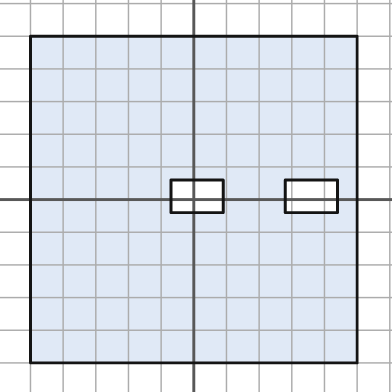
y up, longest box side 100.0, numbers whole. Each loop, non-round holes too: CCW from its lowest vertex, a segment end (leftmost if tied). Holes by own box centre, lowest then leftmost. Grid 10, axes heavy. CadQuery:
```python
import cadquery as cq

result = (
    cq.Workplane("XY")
    .moveTo(-50.0, -50.0)
    .lineTo(50.0, -50.0)
    .lineTo(50.0, 50.0)
    .lineTo(-50.0, 50.0)
    .close()
    .moveTo(-7.0, -4.0)
    .lineTo(9.0, -4.0)
    .lineTo(9.0, 6.0)
    .lineTo(-7.0, 6.0)
    .close()
    .moveTo(28.0, -4.0)
    .lineTo(44.0, -4.0)
    .lineTo(44.0, 6.0)
    .lineTo(28.0, 6.0)
    .close()
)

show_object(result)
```